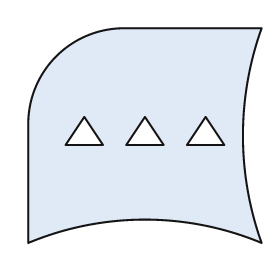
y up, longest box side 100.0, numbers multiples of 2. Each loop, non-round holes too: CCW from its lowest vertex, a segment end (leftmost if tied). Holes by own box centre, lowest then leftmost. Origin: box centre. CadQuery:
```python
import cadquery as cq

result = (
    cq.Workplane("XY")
    .moveTo(-50.0, -46.0)
    .threePointArc((0.0, -36.0), (50.0, -46.0))
    .threePointArc((42.0, 0.0), (50.0, 46.0))
    .lineTo(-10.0, 46.0)
    .threePointArc((-38.0, 34.0), (-50.0, 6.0))
    .close()
    .moveTo(-34.0, -4.0)
    .lineTo(-18.0, -4.0)
    .lineTo(-26.0, 8.0)
    .close()
    .moveTo(-8.0, -4.0)
    .lineTo(8.0, -4.0)
    .lineTo(0.0, 8.0)
    .close()
    .moveTo(18.0, -4.0)
    .lineTo(34.0, -4.0)
    .lineTo(26.0, 8.0)
    .close()
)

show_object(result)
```